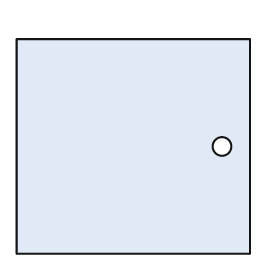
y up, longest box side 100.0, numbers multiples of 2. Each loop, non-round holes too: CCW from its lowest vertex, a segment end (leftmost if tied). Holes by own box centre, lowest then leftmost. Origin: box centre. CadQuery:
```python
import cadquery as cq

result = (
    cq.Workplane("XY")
    .moveTo(-50.0, -46.0)
    .lineTo(50.0, -46.0)
    .lineTo(50.0, 46.0)
    .lineTo(-50.0, 46.0)
    .close()
    .moveTo(38.0, 0.0)
    .circle(4.0)
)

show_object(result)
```